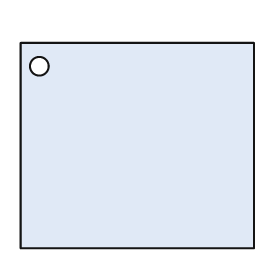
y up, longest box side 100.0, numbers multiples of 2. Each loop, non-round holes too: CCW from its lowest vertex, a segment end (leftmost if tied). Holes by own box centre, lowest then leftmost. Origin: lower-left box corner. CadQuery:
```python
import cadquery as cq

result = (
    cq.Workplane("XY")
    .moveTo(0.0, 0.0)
    .lineTo(100.0, 0.0)
    .lineTo(100.0, 88.0)
    .lineTo(0.0, 88.0)
    .close()
    .moveTo(8.0, 78.0)
    .circle(4.0)
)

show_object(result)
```